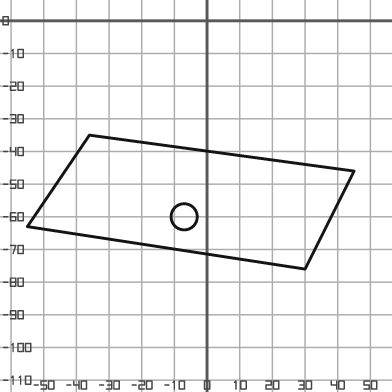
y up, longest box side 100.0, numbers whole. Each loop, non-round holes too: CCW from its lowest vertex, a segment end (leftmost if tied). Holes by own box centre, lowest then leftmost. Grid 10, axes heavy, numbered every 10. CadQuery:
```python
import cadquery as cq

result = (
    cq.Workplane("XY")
    .moveTo(30.0, -76.0)
    .lineTo(45.0, -46.0)
    .lineTo(-36.0, -35.0)
    .lineTo(-55.0, -63.0)
    .close()
    .moveTo(-7.0, -60.0)
    .circle(4.0)
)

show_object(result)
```